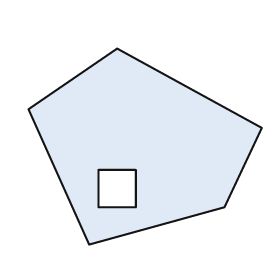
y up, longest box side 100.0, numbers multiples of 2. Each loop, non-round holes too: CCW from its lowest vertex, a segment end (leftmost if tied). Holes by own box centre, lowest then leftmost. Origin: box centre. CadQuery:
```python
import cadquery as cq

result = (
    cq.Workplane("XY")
    .moveTo(-24.0, -42.0)
    .lineTo(34.0, -26.0)
    .lineTo(50.0, 8.0)
    .lineTo(-12.0, 42.0)
    .lineTo(-50.0, 16.0)
    .close()
    .moveTo(-20.0, -26.0)
    .lineTo(-4.0, -26.0)
    .lineTo(-4.0, -10.0)
    .lineTo(-20.0, -10.0)
    .close()
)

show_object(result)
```